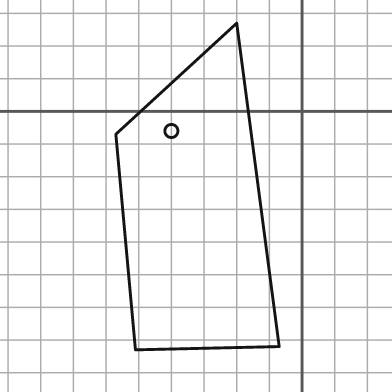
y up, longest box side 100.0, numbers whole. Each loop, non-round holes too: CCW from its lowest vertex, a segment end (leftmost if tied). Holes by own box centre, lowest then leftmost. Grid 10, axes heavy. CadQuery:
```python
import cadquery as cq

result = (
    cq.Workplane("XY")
    .moveTo(-51.0, -73.0)
    .lineTo(-7.0, -72.0)
    .lineTo(-20.0, 27.0)
    .lineTo(-57.0, -7.0)
    .close()
    .moveTo(-40.0, -6.0)
    .circle(2.0)
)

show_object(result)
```